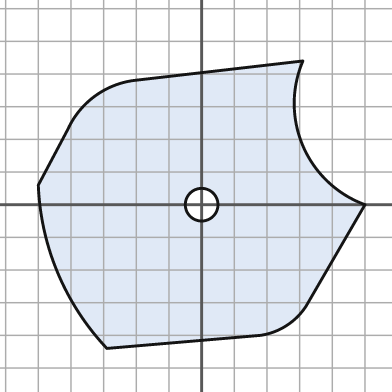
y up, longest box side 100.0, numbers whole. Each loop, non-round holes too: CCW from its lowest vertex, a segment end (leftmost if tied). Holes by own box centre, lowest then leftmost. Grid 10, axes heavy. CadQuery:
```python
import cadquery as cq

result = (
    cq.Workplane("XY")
    .moveTo(-29.0, -44.0)
    .lineTo(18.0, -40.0)
    .threePointArc((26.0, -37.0), (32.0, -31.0))
    .lineTo(50.0, 0.0)
    .threePointArc((31.0, 18.0), (31.0, 44.0))
    .lineTo(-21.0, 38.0)
    .threePointArc((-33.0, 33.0), (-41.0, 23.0))
    .lineTo(-50.0, 6.0)
    .threePointArc((-44.0, -21.0), (-29.0, -44.0))
    .close()
    .moveTo(0.0, 0.0)
    .circle(5.0)
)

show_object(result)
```